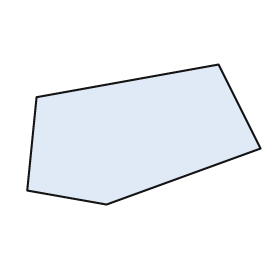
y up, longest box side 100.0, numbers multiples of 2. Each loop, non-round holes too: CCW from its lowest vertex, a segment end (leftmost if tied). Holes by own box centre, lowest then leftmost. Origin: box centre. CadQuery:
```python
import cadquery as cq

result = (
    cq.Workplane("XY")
    .moveTo(-16.0, -30.0)
    .lineTo(50.0, -6.0)
    .lineTo(32.0, 30.0)
    .lineTo(-46.0, 16.0)
    .lineTo(-50.0, -24.0)
    .close()
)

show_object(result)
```